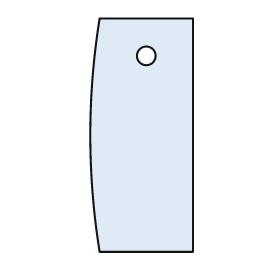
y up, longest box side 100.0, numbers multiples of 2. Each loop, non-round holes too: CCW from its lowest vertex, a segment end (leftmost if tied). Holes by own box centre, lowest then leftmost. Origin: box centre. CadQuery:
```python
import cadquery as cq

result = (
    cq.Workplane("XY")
    .moveTo(-18.0, -50.0)
    .lineTo(22.0, -50.0)
    .lineTo(22.0, 50.0)
    .lineTo(-18.0, 50.0)
    .threePointArc((-22.0, 0.0), (-18.0, -50.0))
    .close()
    .moveTo(2.0, 34.0)
    .circle(4.0)
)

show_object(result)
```